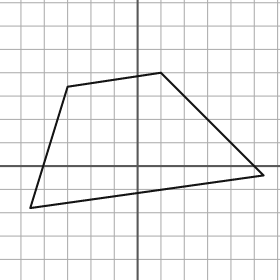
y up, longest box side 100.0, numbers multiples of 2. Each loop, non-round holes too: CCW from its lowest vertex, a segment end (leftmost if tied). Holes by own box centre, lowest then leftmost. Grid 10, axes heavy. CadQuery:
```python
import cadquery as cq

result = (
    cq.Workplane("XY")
    .moveTo(-46.0, -18.0)
    .lineTo(54.0, -4.0)
    .lineTo(10.0, 40.0)
    .lineTo(-30.0, 34.0)
    .close()
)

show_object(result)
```